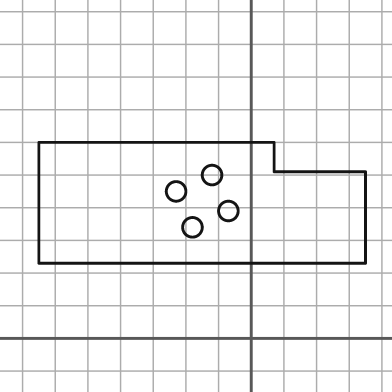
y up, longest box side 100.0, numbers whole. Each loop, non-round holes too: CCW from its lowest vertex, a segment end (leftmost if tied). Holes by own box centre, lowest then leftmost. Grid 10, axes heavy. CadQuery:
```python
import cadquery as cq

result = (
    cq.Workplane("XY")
    .moveTo(-65.0, 23.0)
    .lineTo(35.0, 23.0)
    .lineTo(35.0, 51.0)
    .lineTo(7.0, 51.0)
    .lineTo(7.0, 60.0)
    .lineTo(-65.0, 60.0)
    .close()
    .moveTo(-18.0, 34.0)
    .circle(3.0)
    .moveTo(-7.0, 39.0)
    .circle(3.0)
    .moveTo(-23.0, 45.0)
    .circle(3.0)
    .moveTo(-12.0, 50.0)
    .circle(3.0)
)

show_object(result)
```